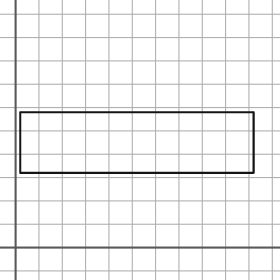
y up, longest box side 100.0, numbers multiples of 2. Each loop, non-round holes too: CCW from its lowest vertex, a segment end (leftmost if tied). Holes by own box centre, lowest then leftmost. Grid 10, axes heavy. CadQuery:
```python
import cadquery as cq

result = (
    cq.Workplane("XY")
    .moveTo(2.0, 32.0)
    .lineTo(102.0, 32.0)
    .lineTo(102.0, 58.0)
    .lineTo(2.0, 58.0)
    .close()
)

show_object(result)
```